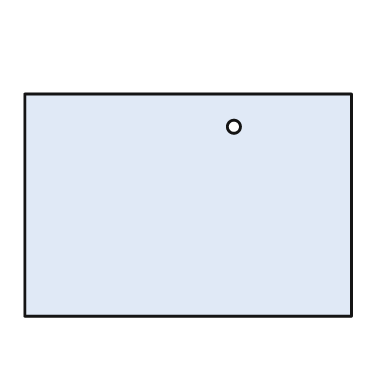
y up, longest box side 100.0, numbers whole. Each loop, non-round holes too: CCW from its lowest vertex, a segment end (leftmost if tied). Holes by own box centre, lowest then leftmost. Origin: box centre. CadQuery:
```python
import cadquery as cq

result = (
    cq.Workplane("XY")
    .moveTo(-50.0, -34.0)
    .lineTo(50.0, -34.0)
    .lineTo(50.0, 34.0)
    .lineTo(-50.0, 34.0)
    .close()
    .moveTo(14.0, 24.0)
    .circle(2.0)
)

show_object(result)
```